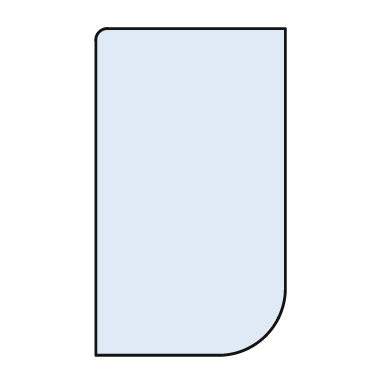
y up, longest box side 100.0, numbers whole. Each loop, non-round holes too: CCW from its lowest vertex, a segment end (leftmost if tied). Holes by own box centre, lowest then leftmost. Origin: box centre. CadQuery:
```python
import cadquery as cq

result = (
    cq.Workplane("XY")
    .moveTo(-29.0, -50.0)
    .lineTo(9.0, -50.0)
    .threePointArc((23.0, -44.0), (29.0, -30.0))
    .lineTo(29.0, 50.0)
    .lineTo(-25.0, 50.0)
    .threePointArc((-28.0, 49.0), (-29.0, 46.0))
    .close()
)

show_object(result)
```